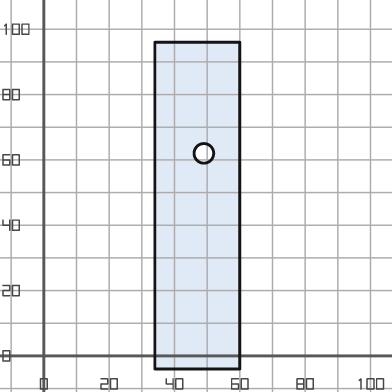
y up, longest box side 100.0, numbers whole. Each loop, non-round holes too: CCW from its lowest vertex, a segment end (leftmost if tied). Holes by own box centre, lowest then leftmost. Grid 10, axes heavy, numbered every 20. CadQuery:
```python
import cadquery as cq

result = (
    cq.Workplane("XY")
    .moveTo(34.0, -4.0)
    .lineTo(60.0, -4.0)
    .lineTo(60.0, 96.0)
    .lineTo(34.0, 96.0)
    .close()
    .moveTo(49.0, 62.0)
    .circle(3.0)
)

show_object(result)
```